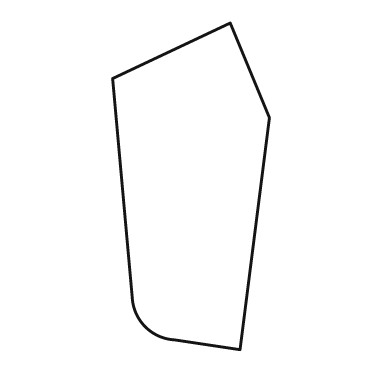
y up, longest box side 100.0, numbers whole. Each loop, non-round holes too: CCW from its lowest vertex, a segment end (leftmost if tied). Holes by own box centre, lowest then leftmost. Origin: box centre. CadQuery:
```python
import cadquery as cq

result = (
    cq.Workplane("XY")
    .moveTo(15.0, -50.0)
    .lineTo(24.0, 21.0)
    .lineTo(12.0, 50.0)
    .lineTo(-24.0, 33.0)
    .lineTo(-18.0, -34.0)
    .threePointArc((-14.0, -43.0), (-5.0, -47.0))
    .close()
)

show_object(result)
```